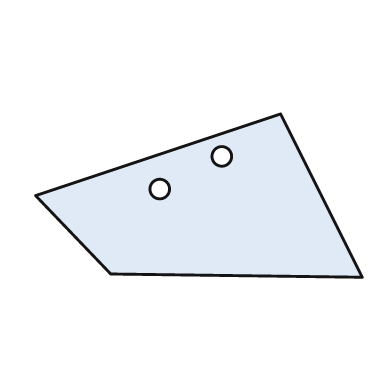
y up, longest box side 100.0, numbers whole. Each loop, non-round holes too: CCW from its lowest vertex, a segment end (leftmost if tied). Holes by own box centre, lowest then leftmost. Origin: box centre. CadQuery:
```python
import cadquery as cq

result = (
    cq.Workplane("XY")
    .moveTo(50.0, -25.0)
    .lineTo(25.0, 25.0)
    .lineTo(-50.0, 0.0)
    .lineTo(-27.0, -24.0)
    .close()
    .moveTo(-12.0, 2.0)
    .circle(3.0)
    .moveTo(7.0, 12.0)
    .circle(3.0)
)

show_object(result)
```